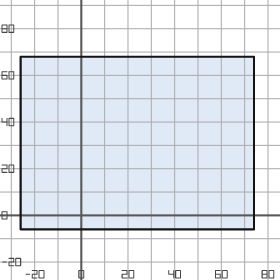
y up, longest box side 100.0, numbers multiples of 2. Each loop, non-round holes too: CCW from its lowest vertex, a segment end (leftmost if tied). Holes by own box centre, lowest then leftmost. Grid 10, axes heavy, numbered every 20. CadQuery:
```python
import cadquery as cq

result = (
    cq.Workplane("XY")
    .moveTo(-26.0, -6.0)
    .lineTo(74.0, -6.0)
    .lineTo(74.0, 68.0)
    .lineTo(-26.0, 68.0)
    .close()
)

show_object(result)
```